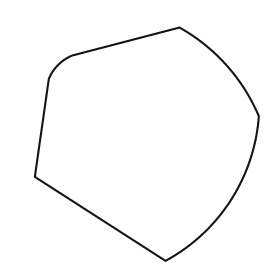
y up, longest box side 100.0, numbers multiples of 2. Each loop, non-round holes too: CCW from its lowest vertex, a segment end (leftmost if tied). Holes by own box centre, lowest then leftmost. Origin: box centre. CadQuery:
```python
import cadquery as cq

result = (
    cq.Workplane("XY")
    .moveTo(8.0, -50.0)
    .threePointArc((36.0, -24.0), (48.0, 12.0))
    .threePointArc((34.0, 34.0), (14.0, 50.0))
    .lineTo(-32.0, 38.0)
    .threePointArc((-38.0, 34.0), (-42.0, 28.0))
    .lineTo(-48.0, -14.0)
    .close()
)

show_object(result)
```